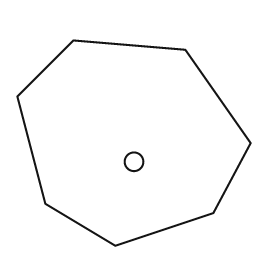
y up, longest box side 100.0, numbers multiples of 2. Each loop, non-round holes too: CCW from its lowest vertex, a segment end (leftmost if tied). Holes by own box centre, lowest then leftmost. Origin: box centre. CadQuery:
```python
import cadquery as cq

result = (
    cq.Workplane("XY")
    .moveTo(-8.0, -44.0)
    .lineTo(34.0, -30.0)
    .lineTo(50.0, 0.0)
    .lineTo(22.0, 40.0)
    .lineTo(-26.0, 44.0)
    .lineTo(-50.0, 20.0)
    .lineTo(-38.0, -26.0)
    .close()
    .moveTo(0.0, -8.0)
    .circle(4.0)
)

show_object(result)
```